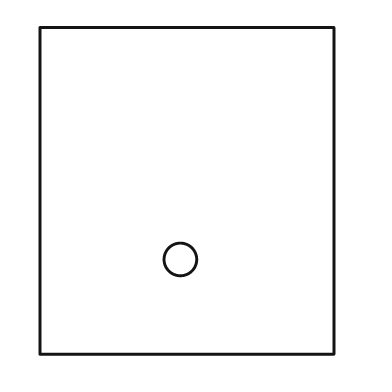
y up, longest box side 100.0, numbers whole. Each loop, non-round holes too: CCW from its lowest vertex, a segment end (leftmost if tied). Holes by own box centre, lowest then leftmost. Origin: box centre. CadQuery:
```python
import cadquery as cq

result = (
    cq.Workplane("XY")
    .moveTo(-45.0, -50.0)
    .lineTo(45.0, -50.0)
    .lineTo(45.0, 50.0)
    .lineTo(-45.0, 50.0)
    .close()
    .moveTo(-2.0, -21.0)
    .circle(5.0)
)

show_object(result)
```